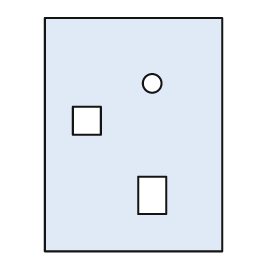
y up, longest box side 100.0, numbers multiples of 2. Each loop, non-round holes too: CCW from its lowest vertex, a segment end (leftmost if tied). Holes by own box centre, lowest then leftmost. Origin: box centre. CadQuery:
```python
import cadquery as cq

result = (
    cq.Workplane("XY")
    .moveTo(-38.0, -50.0)
    .lineTo(38.0, -50.0)
    .lineTo(38.0, 50.0)
    .lineTo(-38.0, 50.0)
    .close()
    .moveTo(2.0, -34.0)
    .lineTo(14.0, -34.0)
    .lineTo(14.0, -18.0)
    .lineTo(2.0, -18.0)
    .close()
    .moveTo(-26.0, 0.0)
    .lineTo(-14.0, 0.0)
    .lineTo(-14.0, 12.0)
    .lineTo(-26.0, 12.0)
    .close()
    .moveTo(8.0, 22.0)
    .circle(4.0)
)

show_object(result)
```